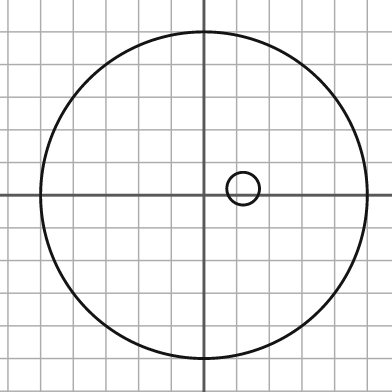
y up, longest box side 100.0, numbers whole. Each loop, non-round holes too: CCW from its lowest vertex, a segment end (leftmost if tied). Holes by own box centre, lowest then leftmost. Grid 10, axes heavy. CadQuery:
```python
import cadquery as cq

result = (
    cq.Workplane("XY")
    .moveTo(0.0, 0.0)
    .circle(50.0)
    .moveTo(12.0, 2.0)
    .circle(5.0)
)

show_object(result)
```